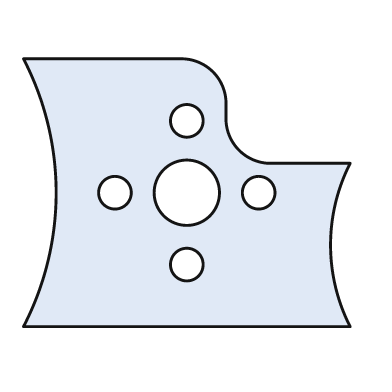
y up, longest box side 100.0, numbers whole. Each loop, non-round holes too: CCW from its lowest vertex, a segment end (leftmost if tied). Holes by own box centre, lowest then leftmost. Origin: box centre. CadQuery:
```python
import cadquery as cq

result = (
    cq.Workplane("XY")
    .moveTo(-50.0, -41.0)
    .lineTo(50.0, -41.0)
    .threePointArc((44.0, -16.0), (50.0, 9.0))
    .lineTo(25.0, 9.0)
    .threePointArc((16.0, 13.0), (12.0, 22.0))
    .lineTo(12.0, 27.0)
    .threePointArc((8.0, 37.0), (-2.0, 41.0))
    .lineTo(-50.0, 41.0)
    .threePointArc((-40.0, 0.0), (-50.0, -41.0))
    .close()
    .moveTo(0.0, -22.0)
    .circle(5.0)
    .moveTo(-22.0, 0.0)
    .circle(5.0)
    .moveTo(0.0, 0.0)
    .circle(10.0)
    .moveTo(22.0, 0.0)
    .circle(5.0)
    .moveTo(0.0, 22.0)
    .circle(5.0)
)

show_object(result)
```